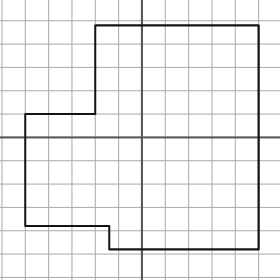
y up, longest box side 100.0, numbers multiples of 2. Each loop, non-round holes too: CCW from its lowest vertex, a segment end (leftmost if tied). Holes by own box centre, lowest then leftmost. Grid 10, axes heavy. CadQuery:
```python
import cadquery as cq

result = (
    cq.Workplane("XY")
    .moveTo(-14.0, -48.0)
    .lineTo(50.0, -48.0)
    .lineTo(50.0, 48.0)
    .lineTo(-20.0, 48.0)
    .lineTo(-20.0, 10.0)
    .lineTo(-50.0, 10.0)
    .lineTo(-50.0, -38.0)
    .lineTo(-14.0, -38.0)
    .close()
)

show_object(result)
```